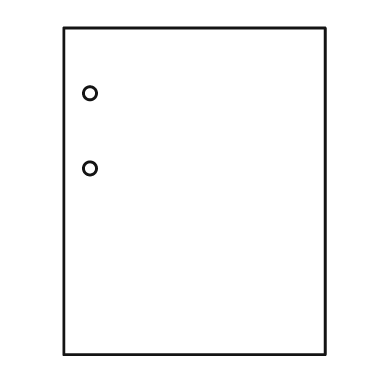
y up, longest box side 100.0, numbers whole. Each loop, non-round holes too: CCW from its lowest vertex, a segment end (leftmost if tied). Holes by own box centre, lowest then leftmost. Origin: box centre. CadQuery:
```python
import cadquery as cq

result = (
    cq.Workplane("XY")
    .moveTo(-40.0, -50.0)
    .lineTo(40.0, -50.0)
    .lineTo(40.0, 50.0)
    .lineTo(-40.0, 50.0)
    .close()
    .moveTo(-32.0, 7.0)
    .circle(2.0)
    .moveTo(-32.0, 30.0)
    .circle(2.0)
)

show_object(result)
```